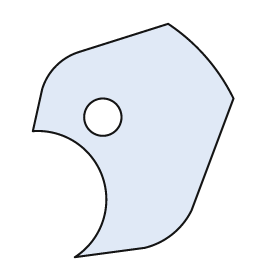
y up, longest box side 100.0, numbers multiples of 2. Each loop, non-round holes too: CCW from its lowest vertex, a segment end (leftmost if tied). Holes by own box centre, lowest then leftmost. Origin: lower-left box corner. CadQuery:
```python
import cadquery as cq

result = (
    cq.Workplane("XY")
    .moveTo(18.0, 0.0)
    .lineTo(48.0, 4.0)
    .threePointArc((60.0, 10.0), (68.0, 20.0))
    .lineTo(86.0, 68.0)
    .threePointArc((74.0, 86.0), (58.0, 100.0))
    .lineTo(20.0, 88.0)
    .threePointArc((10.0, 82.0), (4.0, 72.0))
    .lineTo(0.0, 54.0)
    .threePointArc((30.0, 34.0), (18.0, 0.0))
    .close()
    .moveTo(30.0, 60.0)
    .circle(8.0)
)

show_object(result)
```